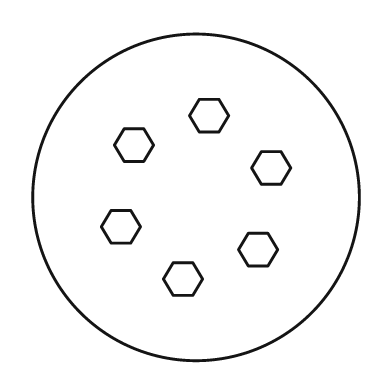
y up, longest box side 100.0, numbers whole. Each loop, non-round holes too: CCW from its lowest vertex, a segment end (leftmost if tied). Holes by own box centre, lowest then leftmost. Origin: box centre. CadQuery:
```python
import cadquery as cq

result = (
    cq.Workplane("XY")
    .moveTo(0.0, 0.0)
    .circle(50.0)
    .moveTo(-7.0, -30.0)
    .lineTo(-1.0, -30.0)
    .lineTo(2.0, -25.0)
    .lineTo(-1.0, -20.0)
    .lineTo(-7.0, -20.0)
    .lineTo(-10.0, -25.0)
    .close()
    .moveTo(16.0, -21.0)
    .lineTo(22.0, -21.0)
    .lineTo(25.0, -16.0)
    .lineTo(22.0, -11.0)
    .lineTo(16.0, -11.0)
    .lineTo(13.0, -16.0)
    .close()
    .moveTo(-26.0, -14.0)
    .lineTo(-20.0, -14.0)
    .lineTo(-17.0, -9.0)
    .lineTo(-20.0, -4.0)
    .lineTo(-26.0, -4.0)
    .lineTo(-29.0, -9.0)
    .close()
    .moveTo(20.0, 4.0)
    .lineTo(26.0, 4.0)
    .lineTo(29.0, 9.0)
    .lineTo(26.0, 14.0)
    .lineTo(20.0, 14.0)
    .lineTo(17.0, 9.0)
    .close()
    .moveTo(-22.0, 11.0)
    .lineTo(-16.0, 11.0)
    .lineTo(-13.0, 16.0)
    .lineTo(-16.0, 21.0)
    .lineTo(-22.0, 21.0)
    .lineTo(-25.0, 16.0)
    .close()
    .moveTo(1.0, 20.0)
    .lineTo(7.0, 20.0)
    .lineTo(10.0, 25.0)
    .lineTo(7.0, 30.0)
    .lineTo(1.0, 30.0)
    .lineTo(-2.0, 25.0)
    .close()
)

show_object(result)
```